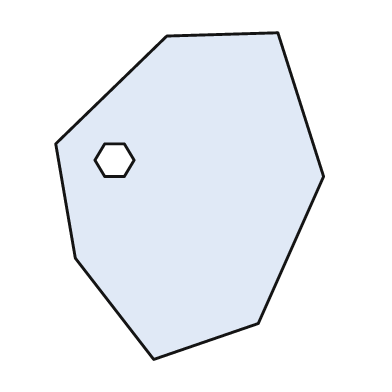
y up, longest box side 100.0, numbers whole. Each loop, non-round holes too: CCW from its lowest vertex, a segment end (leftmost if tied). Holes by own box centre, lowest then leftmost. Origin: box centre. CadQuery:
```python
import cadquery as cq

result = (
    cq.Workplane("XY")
    .moveTo(-11.0, -50.0)
    .lineTo(21.0, -39.0)
    .lineTo(41.0, 6.0)
    .lineTo(27.0, 50.0)
    .lineTo(-7.0, 49.0)
    .lineTo(-41.0, 16.0)
    .lineTo(-35.0, -19.0)
    .close()
    .moveTo(-26.0, 6.0)
    .lineTo(-20.0, 6.0)
    .lineTo(-17.0, 11.0)
    .lineTo(-20.0, 16.0)
    .lineTo(-26.0, 16.0)
    .lineTo(-29.0, 11.0)
    .close()
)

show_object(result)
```